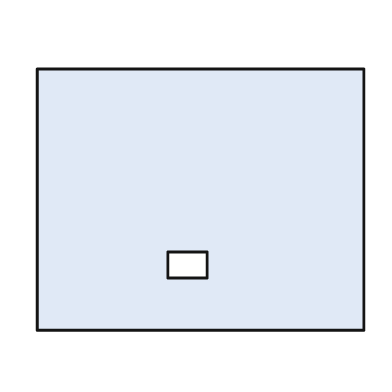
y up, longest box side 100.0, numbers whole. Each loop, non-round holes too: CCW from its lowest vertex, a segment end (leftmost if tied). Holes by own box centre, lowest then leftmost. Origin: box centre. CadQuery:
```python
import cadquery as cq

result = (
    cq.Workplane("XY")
    .moveTo(-50.0, -40.0)
    .lineTo(50.0, -40.0)
    .lineTo(50.0, 40.0)
    .lineTo(-50.0, 40.0)
    .close()
    .moveTo(-10.0, -24.0)
    .lineTo(2.0, -24.0)
    .lineTo(2.0, -16.0)
    .lineTo(-10.0, -16.0)
    .close()
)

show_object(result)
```